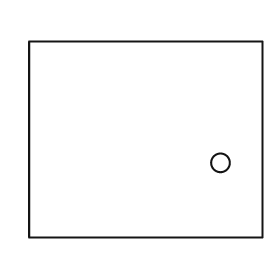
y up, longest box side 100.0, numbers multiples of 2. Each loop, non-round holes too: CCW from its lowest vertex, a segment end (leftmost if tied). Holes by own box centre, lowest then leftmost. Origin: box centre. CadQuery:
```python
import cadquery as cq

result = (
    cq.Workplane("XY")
    .moveTo(-50.0, -42.0)
    .lineTo(50.0, -42.0)
    .lineTo(50.0, 42.0)
    .lineTo(-50.0, 42.0)
    .close()
    .moveTo(32.0, -10.0)
    .circle(4.0)
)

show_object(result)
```